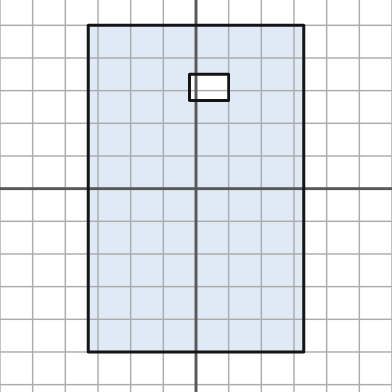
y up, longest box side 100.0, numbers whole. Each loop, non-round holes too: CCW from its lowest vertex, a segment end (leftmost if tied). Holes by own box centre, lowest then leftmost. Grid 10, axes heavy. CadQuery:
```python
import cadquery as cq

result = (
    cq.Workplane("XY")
    .moveTo(-33.0, -50.0)
    .lineTo(33.0, -50.0)
    .lineTo(33.0, 50.0)
    .lineTo(-33.0, 50.0)
    .close()
    .moveTo(-2.0, 27.0)
    .lineTo(10.0, 27.0)
    .lineTo(10.0, 35.0)
    .lineTo(-2.0, 35.0)
    .close()
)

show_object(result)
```